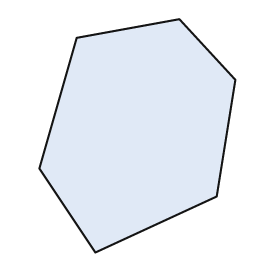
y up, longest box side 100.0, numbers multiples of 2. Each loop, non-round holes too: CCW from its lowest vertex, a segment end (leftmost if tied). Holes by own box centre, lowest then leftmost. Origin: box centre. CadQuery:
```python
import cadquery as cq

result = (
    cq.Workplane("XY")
    .moveTo(-18.0, -50.0)
    .lineTo(34.0, -26.0)
    .lineTo(42.0, 24.0)
    .lineTo(18.0, 50.0)
    .lineTo(-26.0, 42.0)
    .lineTo(-42.0, -14.0)
    .close()
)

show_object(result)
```